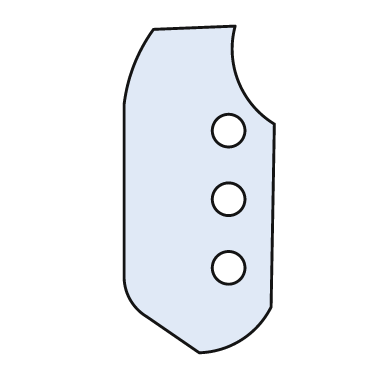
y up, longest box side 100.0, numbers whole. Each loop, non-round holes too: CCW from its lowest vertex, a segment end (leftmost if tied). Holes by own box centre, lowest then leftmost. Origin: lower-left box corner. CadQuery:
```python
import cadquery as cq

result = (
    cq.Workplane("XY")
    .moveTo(23.0, 0.0)
    .threePointArc((36.0, 4.0), (45.0, 14.0))
    .lineTo(46.0, 70.0)
    .threePointArc((35.0, 83.0), (34.0, 100.0))
    .lineTo(9.0, 99.0)
    .threePointArc((3.0, 88.0), (0.0, 76.0))
    .lineTo(0.0, 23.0)
    .threePointArc((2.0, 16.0), (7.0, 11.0))
    .close()
    .moveTo(32.0, 26.0)
    .circle(5.0)
    .moveTo(32.0, 47.0)
    .circle(5.0)
    .moveTo(32.0, 68.0)
    .circle(5.0)
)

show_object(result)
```